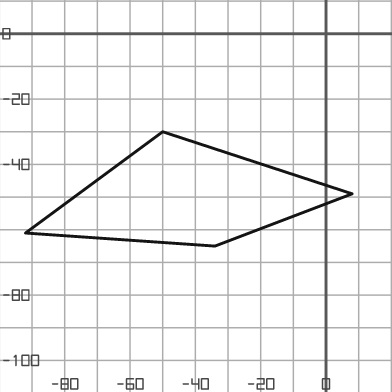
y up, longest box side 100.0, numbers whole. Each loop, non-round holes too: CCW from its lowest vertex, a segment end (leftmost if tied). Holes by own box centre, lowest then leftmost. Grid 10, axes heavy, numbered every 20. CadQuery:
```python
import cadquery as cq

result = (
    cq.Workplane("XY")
    .moveTo(-34.0, -65.0)
    .lineTo(8.0, -49.0)
    .lineTo(-50.0, -30.0)
    .lineTo(-92.0, -61.0)
    .close()
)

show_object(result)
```